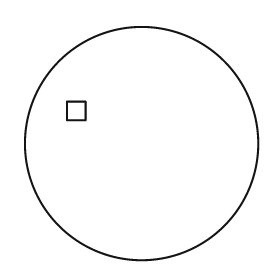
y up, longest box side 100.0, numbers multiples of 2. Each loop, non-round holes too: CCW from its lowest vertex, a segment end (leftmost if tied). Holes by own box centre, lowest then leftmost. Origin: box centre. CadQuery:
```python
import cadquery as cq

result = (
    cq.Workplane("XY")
    .moveTo(0.0, 0.0)
    .circle(50.0)
    .moveTo(-32.0, 10.0)
    .lineTo(-24.0, 10.0)
    .lineTo(-24.0, 18.0)
    .lineTo(-32.0, 18.0)
    .close()
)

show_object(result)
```